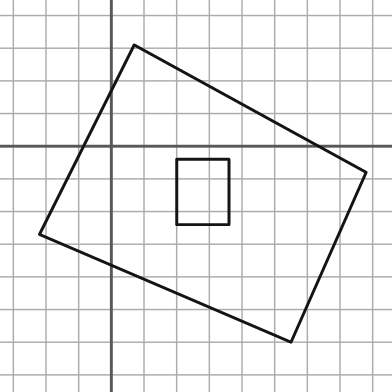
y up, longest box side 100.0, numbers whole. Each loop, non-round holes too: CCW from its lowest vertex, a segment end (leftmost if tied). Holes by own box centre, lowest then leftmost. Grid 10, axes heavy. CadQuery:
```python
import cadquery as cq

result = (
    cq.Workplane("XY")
    .moveTo(55.0, -60.0)
    .lineTo(78.0, -8.0)
    .lineTo(7.0, 31.0)
    .lineTo(-22.0, -27.0)
    .close()
    .moveTo(20.0, -24.0)
    .lineTo(36.0, -24.0)
    .lineTo(36.0, -4.0)
    .lineTo(20.0, -4.0)
    .close()
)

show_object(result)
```